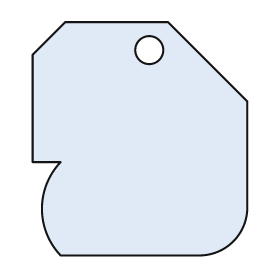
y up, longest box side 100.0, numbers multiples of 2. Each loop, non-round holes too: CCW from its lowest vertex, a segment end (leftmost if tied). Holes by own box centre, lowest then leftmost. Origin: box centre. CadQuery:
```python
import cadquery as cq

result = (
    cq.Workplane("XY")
    .moveTo(-34.0, -50.0)
    .lineTo(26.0, -50.0)
    .threePointArc((40.0, -44.0), (46.0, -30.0))
    .lineTo(46.0, 16.0)
    .lineTo(12.0, 50.0)
    .lineTo(-32.0, 50.0)
    .lineTo(-46.0, 36.0)
    .lineTo(-46.0, -10.0)
    .lineTo(-34.0, -10.0)
    .threePointArc((-42.0, -30.0), (-34.0, -50.0))
    .close()
    .moveTo(4.0, 38.0)
    .circle(6.0)
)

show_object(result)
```